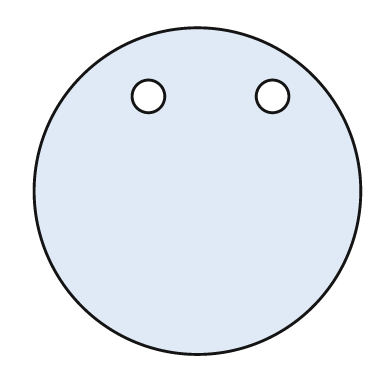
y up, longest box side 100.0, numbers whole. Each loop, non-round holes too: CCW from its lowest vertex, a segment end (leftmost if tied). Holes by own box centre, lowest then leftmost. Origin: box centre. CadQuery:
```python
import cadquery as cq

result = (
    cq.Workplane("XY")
    .moveTo(0.0, 0.0)
    .circle(50.0)
    .moveTo(-15.0, 29.0)
    .circle(5.0)
    .moveTo(23.0, 29.0)
    .circle(5.0)
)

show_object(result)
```